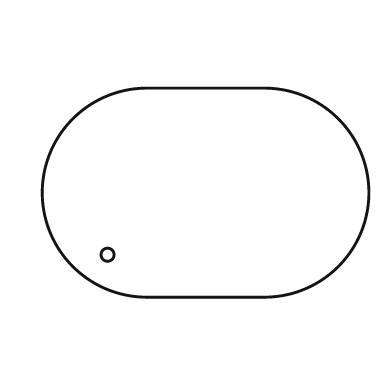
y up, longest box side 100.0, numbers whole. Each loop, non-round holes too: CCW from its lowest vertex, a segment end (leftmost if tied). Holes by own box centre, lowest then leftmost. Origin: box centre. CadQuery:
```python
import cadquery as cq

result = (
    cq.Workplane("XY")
    .moveTo(-18.0, -32.0)
    .lineTo(18.0, -32.0)
    .threePointArc((50.0, 0.0), (18.0, 32.0))
    .lineTo(-18.0, 32.0)
    .threePointArc((-50.0, 0.0), (-18.0, -32.0))
    .close()
    .moveTo(-30.0, -19.0)
    .circle(2.0)
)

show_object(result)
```